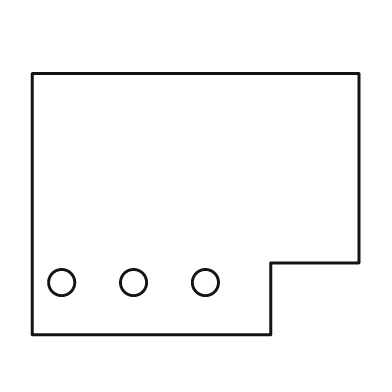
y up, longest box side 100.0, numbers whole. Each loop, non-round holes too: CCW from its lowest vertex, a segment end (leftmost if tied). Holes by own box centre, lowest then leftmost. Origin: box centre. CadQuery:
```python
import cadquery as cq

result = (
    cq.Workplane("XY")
    .moveTo(-50.0, -40.0)
    .lineTo(23.0, -40.0)
    .lineTo(23.0, -18.0)
    .lineTo(50.0, -18.0)
    .lineTo(50.0, 40.0)
    .lineTo(-50.0, 40.0)
    .close()
    .moveTo(-41.0, -24.0)
    .circle(4.0)
    .moveTo(-19.0, -24.0)
    .circle(4.0)
    .moveTo(3.0, -24.0)
    .circle(4.0)
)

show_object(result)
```